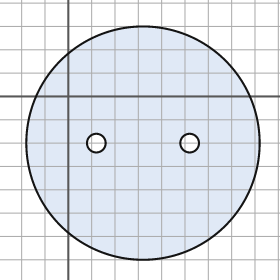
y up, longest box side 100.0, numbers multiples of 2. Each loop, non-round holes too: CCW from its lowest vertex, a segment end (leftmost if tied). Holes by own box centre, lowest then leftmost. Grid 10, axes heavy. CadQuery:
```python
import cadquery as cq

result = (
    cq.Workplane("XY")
    .moveTo(32.0, -20.0)
    .circle(50.0)
    .moveTo(12.0, -20.0)
    .circle(4.0)
    .moveTo(52.0, -20.0)
    .circle(4.0)
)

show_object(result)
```